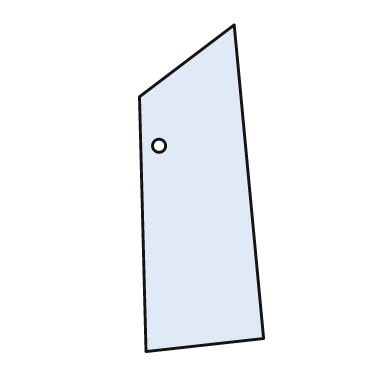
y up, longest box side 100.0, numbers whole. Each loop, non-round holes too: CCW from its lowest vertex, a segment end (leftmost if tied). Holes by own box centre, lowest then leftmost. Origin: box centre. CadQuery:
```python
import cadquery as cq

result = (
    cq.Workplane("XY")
    .moveTo(-17.0, -50.0)
    .lineTo(19.0, -46.0)
    .lineTo(10.0, 50.0)
    .lineTo(-19.0, 28.0)
    .close()
    .moveTo(-13.0, 13.0)
    .circle(2.0)
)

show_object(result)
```